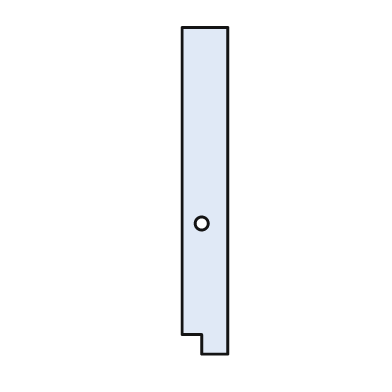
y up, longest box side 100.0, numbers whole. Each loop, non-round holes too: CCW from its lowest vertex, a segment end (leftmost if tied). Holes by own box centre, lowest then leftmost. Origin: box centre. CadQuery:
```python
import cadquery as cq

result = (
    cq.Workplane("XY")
    .moveTo(-1.0, -50.0)
    .lineTo(7.0, -50.0)
    .lineTo(7.0, 50.0)
    .lineTo(-7.0, 50.0)
    .lineTo(-7.0, -44.0)
    .lineTo(-1.0, -44.0)
    .close()
    .moveTo(-1.0, -10.0)
    .circle(2.0)
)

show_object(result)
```